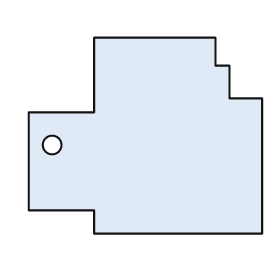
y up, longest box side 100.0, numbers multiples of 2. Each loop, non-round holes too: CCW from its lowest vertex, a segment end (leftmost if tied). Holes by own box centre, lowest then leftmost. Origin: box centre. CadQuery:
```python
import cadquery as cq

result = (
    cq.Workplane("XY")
    .moveTo(-22.0, -42.0)
    .lineTo(50.0, -42.0)
    .lineTo(50.0, 16.0)
    .lineTo(36.0, 16.0)
    .lineTo(36.0, 30.0)
    .lineTo(30.0, 30.0)
    .lineTo(30.0, 42.0)
    .lineTo(-22.0, 42.0)
    .lineTo(-22.0, 10.0)
    .lineTo(-50.0, 10.0)
    .lineTo(-50.0, -32.0)
    .lineTo(-22.0, -32.0)
    .close()
    .moveTo(-40.0, -4.0)
    .circle(4.0)
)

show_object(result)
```